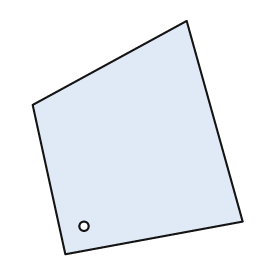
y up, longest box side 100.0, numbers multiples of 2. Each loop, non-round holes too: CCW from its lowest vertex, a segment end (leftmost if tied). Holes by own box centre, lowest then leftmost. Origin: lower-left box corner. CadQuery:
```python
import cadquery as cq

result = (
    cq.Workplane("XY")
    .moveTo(14.0, 0.0)
    .lineTo(90.0, 14.0)
    .lineTo(66.0, 100.0)
    .lineTo(0.0, 64.0)
    .close()
    .moveTo(22.0, 12.0)
    .circle(2.0)
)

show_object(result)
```